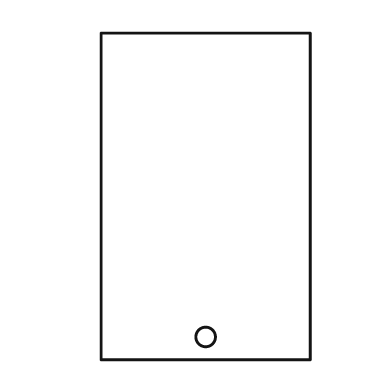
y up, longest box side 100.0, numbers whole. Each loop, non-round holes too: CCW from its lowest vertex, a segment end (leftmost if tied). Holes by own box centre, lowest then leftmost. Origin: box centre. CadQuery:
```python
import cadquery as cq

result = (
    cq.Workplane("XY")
    .moveTo(-32.0, -50.0)
    .lineTo(32.0, -50.0)
    .lineTo(32.0, 50.0)
    .lineTo(-32.0, 50.0)
    .close()
    .moveTo(0.0, -43.0)
    .circle(3.0)
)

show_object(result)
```